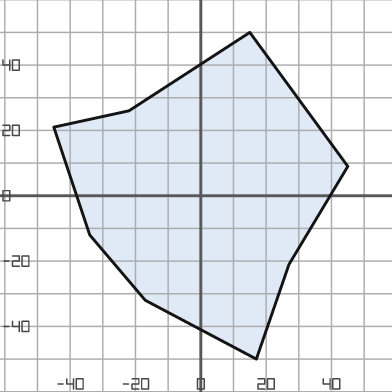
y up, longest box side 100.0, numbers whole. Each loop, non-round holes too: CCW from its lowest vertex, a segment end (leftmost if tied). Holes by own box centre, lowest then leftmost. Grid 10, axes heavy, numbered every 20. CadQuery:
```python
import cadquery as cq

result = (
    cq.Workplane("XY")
    .moveTo(17.0, -50.0)
    .lineTo(27.0, -21.0)
    .lineTo(45.0, 9.0)
    .lineTo(15.0, 50.0)
    .lineTo(-22.0, 26.0)
    .lineTo(-45.0, 21.0)
    .lineTo(-34.0, -12.0)
    .lineTo(-17.0, -32.0)
    .close()
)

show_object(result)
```